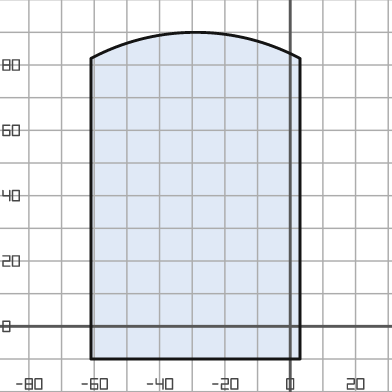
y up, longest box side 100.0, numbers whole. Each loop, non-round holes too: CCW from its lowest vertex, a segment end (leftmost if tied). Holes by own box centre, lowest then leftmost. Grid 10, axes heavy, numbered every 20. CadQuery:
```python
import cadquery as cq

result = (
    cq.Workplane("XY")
    .moveTo(-61.0, -10.0)
    .lineTo(3.0, -10.0)
    .lineTo(3.0, 82.0)
    .threePointArc((-29.0, 90.0), (-61.0, 82.0))
    .close()
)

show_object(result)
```